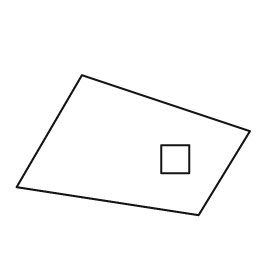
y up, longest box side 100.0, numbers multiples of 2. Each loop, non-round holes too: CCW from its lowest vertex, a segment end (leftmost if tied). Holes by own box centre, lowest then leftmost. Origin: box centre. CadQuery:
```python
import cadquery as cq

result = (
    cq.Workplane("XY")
    .moveTo(28.0, -30.0)
    .lineTo(50.0, 6.0)
    .lineTo(-22.0, 30.0)
    .lineTo(-50.0, -18.0)
    .close()
    .moveTo(12.0, -12.0)
    .lineTo(24.0, -12.0)
    .lineTo(24.0, 0.0)
    .lineTo(12.0, 0.0)
    .close()
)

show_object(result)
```